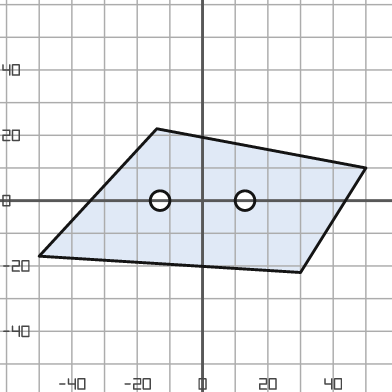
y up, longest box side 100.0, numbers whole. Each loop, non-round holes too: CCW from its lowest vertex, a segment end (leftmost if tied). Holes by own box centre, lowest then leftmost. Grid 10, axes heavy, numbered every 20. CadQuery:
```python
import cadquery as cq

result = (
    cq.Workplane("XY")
    .moveTo(30.0, -22.0)
    .lineTo(50.0, 10.0)
    .lineTo(-14.0, 22.0)
    .lineTo(-50.0, -17.0)
    .close()
    .moveTo(-13.0, 0.0)
    .circle(3.0)
    .moveTo(13.0, 0.0)
    .circle(3.0)
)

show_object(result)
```